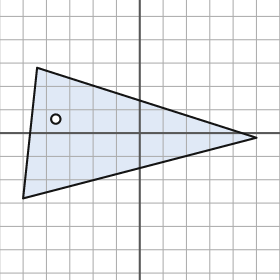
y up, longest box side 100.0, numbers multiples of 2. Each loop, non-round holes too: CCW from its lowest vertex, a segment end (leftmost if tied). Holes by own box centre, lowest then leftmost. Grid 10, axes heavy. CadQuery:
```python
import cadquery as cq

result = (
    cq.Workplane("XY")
    .moveTo(-50.0, -28.0)
    .lineTo(50.0, -2.0)
    .lineTo(-44.0, 28.0)
    .close()
    .moveTo(-36.0, 6.0)
    .circle(2.0)
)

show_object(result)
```